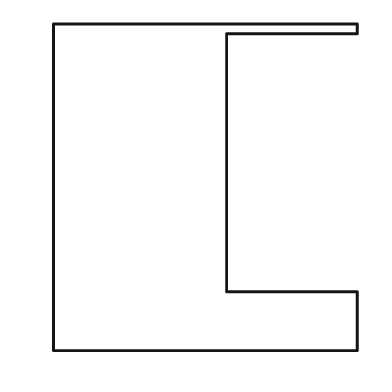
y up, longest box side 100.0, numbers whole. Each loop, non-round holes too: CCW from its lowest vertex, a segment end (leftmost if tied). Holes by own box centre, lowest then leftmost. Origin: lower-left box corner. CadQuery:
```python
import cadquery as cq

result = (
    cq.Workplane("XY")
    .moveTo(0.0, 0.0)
    .lineTo(93.0, 0.0)
    .lineTo(93.0, 18.0)
    .lineTo(53.0, 18.0)
    .lineTo(53.0, 97.0)
    .lineTo(93.0, 97.0)
    .lineTo(93.0, 100.0)
    .lineTo(0.0, 100.0)
    .close()
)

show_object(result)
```